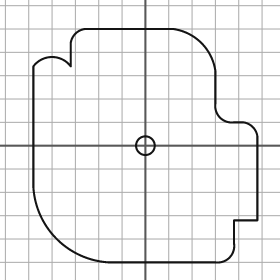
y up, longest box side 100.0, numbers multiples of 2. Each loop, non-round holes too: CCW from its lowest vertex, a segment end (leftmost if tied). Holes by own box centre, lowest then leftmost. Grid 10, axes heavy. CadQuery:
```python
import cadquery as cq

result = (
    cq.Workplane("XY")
    .moveTo(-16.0, -50.0)
    .lineTo(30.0, -50.0)
    .threePointArc((36.0, -48.0), (38.0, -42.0))
    .lineTo(38.0, -32.0)
    .lineTo(48.0, -32.0)
    .lineTo(48.0, 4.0)
    .threePointArc((46.0, 8.0), (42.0, 10.0))
    .lineTo(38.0, 10.0)
    .threePointArc((32.0, 12.0), (30.0, 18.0))
    .lineTo(30.0, 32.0)
    .threePointArc((24.0, 44.0), (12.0, 50.0))
    .lineTo(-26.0, 50.0)
    .threePointArc((-30.0, 48.0), (-32.0, 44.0))
    .lineTo(-32.0, 34.0)
    .threePointArc((-40.0, 38.0), (-48.0, 34.0))
    .lineTo(-48.0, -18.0)
    .threePointArc((-38.0, -40.0), (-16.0, -50.0))
    .close()
    .moveTo(0.0, 0.0)
    .circle(4.0)
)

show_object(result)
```